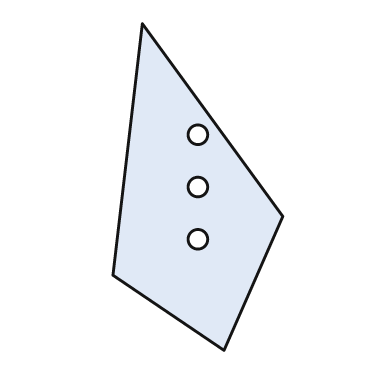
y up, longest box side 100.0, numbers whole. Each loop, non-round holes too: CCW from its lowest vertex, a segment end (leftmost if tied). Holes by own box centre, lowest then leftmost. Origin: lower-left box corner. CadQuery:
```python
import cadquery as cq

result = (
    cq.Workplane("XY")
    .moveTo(34.0, 0.0)
    .lineTo(52.0, 41.0)
    .lineTo(9.0, 100.0)
    .lineTo(0.0, 23.0)
    .close()
    .moveTo(26.0, 34.0)
    .circle(3.0)
    .moveTo(26.0, 50.0)
    .circle(3.0)
    .moveTo(26.0, 66.0)
    .circle(3.0)
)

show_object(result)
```